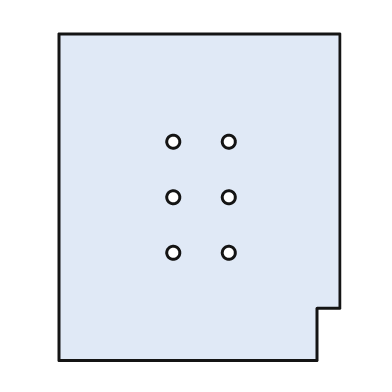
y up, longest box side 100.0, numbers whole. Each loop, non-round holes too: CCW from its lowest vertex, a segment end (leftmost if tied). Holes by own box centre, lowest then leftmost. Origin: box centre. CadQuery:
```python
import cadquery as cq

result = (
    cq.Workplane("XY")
    .moveTo(-43.0, -50.0)
    .lineTo(36.0, -50.0)
    .lineTo(36.0, -34.0)
    .lineTo(43.0, -34.0)
    .lineTo(43.0, 50.0)
    .lineTo(-43.0, 50.0)
    .close()
    .moveTo(-8.0, -17.0)
    .circle(2.0)
    .moveTo(9.0, -17.0)
    .circle(2.0)
    .moveTo(-8.0, 0.0)
    .circle(2.0)
    .moveTo(9.0, 0.0)
    .circle(2.0)
    .moveTo(-8.0, 17.0)
    .circle(2.0)
    .moveTo(9.0, 17.0)
    .circle(2.0)
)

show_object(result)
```